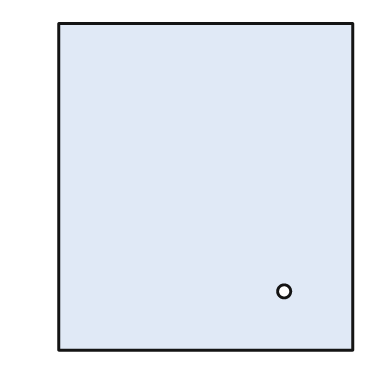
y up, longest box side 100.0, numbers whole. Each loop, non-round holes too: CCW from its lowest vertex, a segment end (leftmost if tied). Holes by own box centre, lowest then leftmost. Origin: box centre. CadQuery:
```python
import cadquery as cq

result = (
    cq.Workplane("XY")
    .moveTo(-45.0, -50.0)
    .lineTo(45.0, -50.0)
    .lineTo(45.0, 50.0)
    .lineTo(-45.0, 50.0)
    .close()
    .moveTo(24.0, -32.0)
    .circle(2.0)
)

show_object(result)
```